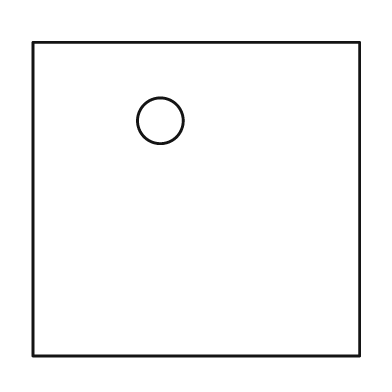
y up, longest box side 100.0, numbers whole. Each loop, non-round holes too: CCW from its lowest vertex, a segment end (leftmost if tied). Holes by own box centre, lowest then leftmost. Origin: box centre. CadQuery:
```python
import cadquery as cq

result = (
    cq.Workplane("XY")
    .moveTo(-50.0, -48.0)
    .lineTo(50.0, -48.0)
    .lineTo(50.0, 48.0)
    .lineTo(-50.0, 48.0)
    .close()
    .moveTo(-11.0, 24.0)
    .circle(7.0)
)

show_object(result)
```